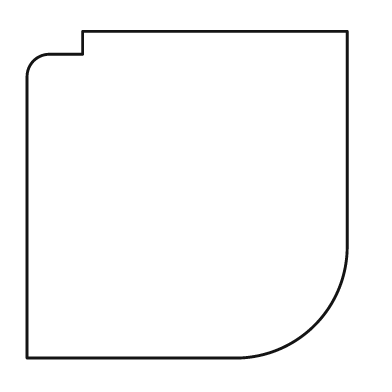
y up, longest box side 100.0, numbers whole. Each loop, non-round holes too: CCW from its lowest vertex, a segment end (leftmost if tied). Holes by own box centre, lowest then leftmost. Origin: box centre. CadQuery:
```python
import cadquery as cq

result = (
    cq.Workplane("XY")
    .moveTo(-49.0, -50.0)
    .lineTo(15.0, -50.0)
    .threePointArc((39.0, -40.0), (49.0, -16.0))
    .lineTo(49.0, 50.0)
    .lineTo(-32.0, 50.0)
    .lineTo(-32.0, 43.0)
    .lineTo(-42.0, 43.0)
    .threePointArc((-47.0, 41.0), (-49.0, 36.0))
    .close()
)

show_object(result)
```